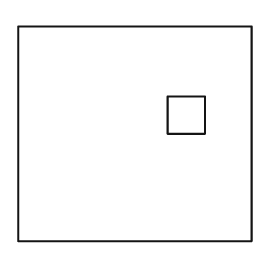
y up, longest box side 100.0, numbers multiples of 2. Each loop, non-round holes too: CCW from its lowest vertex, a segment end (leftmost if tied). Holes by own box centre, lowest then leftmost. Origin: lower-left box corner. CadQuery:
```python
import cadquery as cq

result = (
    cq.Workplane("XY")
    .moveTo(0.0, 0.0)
    .lineTo(100.0, 0.0)
    .lineTo(100.0, 92.0)
    .lineTo(0.0, 92.0)
    .close()
    .moveTo(64.0, 46.0)
    .lineTo(80.0, 46.0)
    .lineTo(80.0, 62.0)
    .lineTo(64.0, 62.0)
    .close()
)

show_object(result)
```